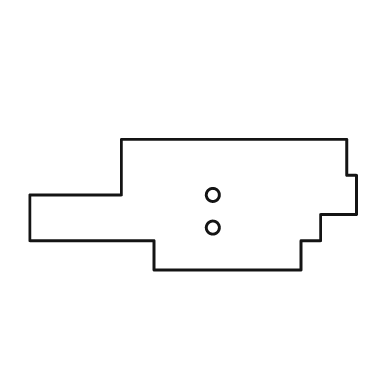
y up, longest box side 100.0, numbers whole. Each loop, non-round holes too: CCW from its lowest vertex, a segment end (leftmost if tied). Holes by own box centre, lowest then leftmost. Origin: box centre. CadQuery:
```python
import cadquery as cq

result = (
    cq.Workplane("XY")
    .moveTo(-12.0, -20.0)
    .lineTo(33.0, -20.0)
    .lineTo(33.0, -11.0)
    .lineTo(39.0, -11.0)
    .lineTo(39.0, -3.0)
    .lineTo(50.0, -3.0)
    .lineTo(50.0, 9.0)
    .lineTo(47.0, 9.0)
    .lineTo(47.0, 20.0)
    .lineTo(-22.0, 20.0)
    .lineTo(-22.0, 3.0)
    .lineTo(-50.0, 3.0)
    .lineTo(-50.0, -11.0)
    .lineTo(-12.0, -11.0)
    .close()
    .moveTo(6.0, -7.0)
    .circle(2.0)
    .moveTo(6.0, 3.0)
    .circle(2.0)
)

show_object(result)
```